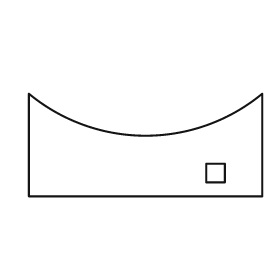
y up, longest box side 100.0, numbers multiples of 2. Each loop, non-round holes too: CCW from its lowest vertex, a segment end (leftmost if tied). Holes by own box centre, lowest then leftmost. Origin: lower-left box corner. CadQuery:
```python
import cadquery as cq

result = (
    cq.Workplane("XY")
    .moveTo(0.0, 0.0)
    .lineTo(100.0, 0.0)
    .lineTo(100.0, 44.0)
    .threePointArc((50.0, 26.0), (0.0, 44.0))
    .close()
    .moveTo(76.0, 6.0)
    .lineTo(84.0, 6.0)
    .lineTo(84.0, 14.0)
    .lineTo(76.0, 14.0)
    .close()
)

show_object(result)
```